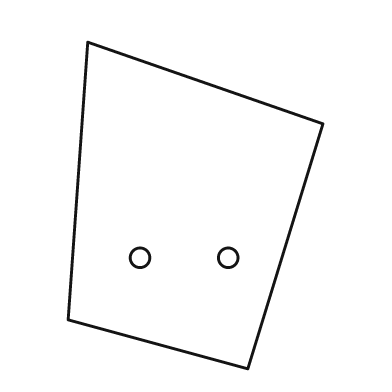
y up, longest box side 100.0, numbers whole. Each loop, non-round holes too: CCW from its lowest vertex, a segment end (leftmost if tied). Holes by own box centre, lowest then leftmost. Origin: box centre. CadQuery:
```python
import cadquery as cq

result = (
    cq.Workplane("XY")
    .moveTo(16.0, -50.0)
    .lineTo(39.0, 25.0)
    .lineTo(-33.0, 50.0)
    .lineTo(-39.0, -35.0)
    .close()
    .moveTo(-17.0, -16.0)
    .circle(3.0)
    .moveTo(10.0, -16.0)
    .circle(3.0)
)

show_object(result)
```